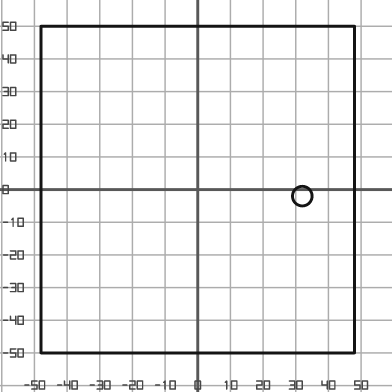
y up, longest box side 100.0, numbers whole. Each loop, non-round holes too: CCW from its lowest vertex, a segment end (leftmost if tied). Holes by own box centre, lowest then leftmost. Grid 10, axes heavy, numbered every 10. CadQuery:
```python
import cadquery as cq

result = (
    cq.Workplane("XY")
    .moveTo(-48.0, -50.0)
    .lineTo(48.0, -50.0)
    .lineTo(48.0, 50.0)
    .lineTo(-48.0, 50.0)
    .close()
    .moveTo(32.0, -2.0)
    .circle(3.0)
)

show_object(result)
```